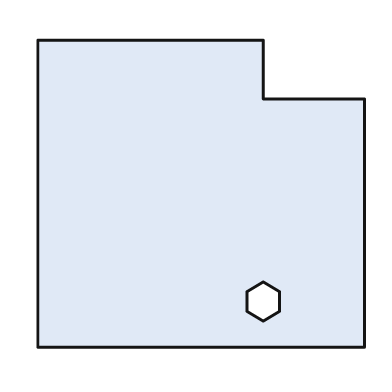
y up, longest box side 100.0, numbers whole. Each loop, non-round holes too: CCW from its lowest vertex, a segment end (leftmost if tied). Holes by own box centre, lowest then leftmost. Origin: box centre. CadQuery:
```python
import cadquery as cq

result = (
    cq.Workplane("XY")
    .moveTo(-50.0, -47.0)
    .lineTo(50.0, -47.0)
    .lineTo(50.0, 29.0)
    .lineTo(19.0, 29.0)
    .lineTo(19.0, 47.0)
    .lineTo(-50.0, 47.0)
    .close()
    .moveTo(19.0, -39.0)
    .lineTo(24.0, -36.0)
    .lineTo(24.0, -30.0)
    .lineTo(19.0, -27.0)
    .lineTo(14.0, -30.0)
    .lineTo(14.0, -36.0)
    .close()
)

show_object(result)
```